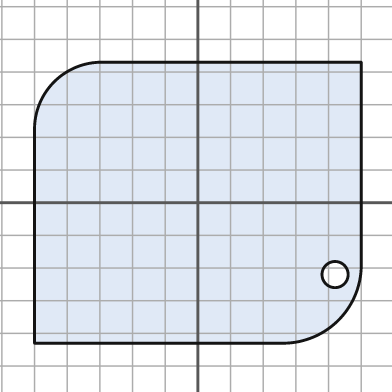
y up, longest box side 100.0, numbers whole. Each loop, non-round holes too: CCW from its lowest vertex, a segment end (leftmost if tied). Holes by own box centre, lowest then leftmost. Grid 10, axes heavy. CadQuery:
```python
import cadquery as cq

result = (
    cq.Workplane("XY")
    .moveTo(-50.0, -43.0)
    .lineTo(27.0, -43.0)
    .threePointArc((43.0, -36.0), (50.0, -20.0))
    .lineTo(50.0, 43.0)
    .lineTo(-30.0, 43.0)
    .threePointArc((-44.0, 37.0), (-50.0, 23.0))
    .close()
    .moveTo(42.0, -22.0)
    .circle(4.0)
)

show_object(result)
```